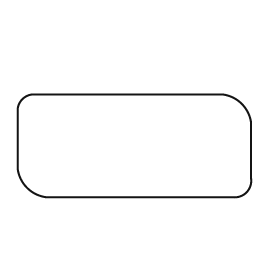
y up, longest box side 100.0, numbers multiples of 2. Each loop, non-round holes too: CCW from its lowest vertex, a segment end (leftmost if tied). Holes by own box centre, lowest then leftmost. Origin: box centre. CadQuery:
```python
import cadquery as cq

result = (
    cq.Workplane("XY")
    .moveTo(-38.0, -22.0)
    .lineTo(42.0, -22.0)
    .threePointArc((48.0, -20.0), (50.0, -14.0))
    .lineTo(50.0, 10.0)
    .threePointArc((46.0, 18.0), (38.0, 22.0))
    .lineTo(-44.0, 22.0)
    .threePointArc((-48.0, 20.0), (-50.0, 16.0))
    .lineTo(-50.0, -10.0)
    .threePointArc((-46.0, -18.0), (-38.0, -22.0))
    .close()
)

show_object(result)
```